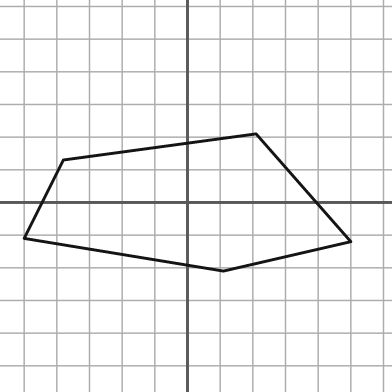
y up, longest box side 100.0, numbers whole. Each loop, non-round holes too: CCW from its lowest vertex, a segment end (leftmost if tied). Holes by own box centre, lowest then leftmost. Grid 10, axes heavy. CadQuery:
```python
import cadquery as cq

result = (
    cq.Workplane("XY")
    .moveTo(11.0, -21.0)
    .lineTo(50.0, -12.0)
    .lineTo(21.0, 21.0)
    .lineTo(-38.0, 13.0)
    .lineTo(-50.0, -11.0)
    .close()
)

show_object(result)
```